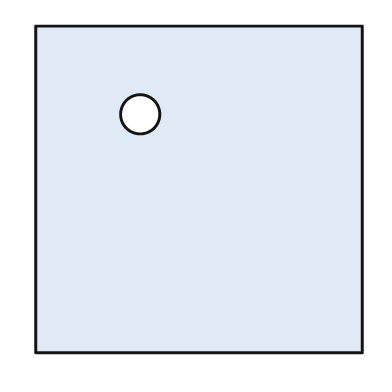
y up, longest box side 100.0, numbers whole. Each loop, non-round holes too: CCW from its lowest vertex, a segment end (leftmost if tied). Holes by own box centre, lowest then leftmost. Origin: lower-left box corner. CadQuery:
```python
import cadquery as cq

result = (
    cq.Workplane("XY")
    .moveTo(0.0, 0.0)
    .lineTo(100.0, 0.0)
    .lineTo(100.0, 100.0)
    .lineTo(0.0, 100.0)
    .close()
    .moveTo(32.0, 73.0)
    .circle(6.0)
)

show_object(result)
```